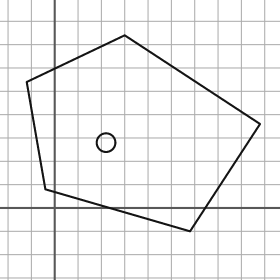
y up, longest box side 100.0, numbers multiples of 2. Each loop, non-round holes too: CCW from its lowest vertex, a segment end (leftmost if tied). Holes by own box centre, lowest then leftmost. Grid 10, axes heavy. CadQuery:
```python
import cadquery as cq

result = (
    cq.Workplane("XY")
    .moveTo(58.0, -10.0)
    .lineTo(88.0, 36.0)
    .lineTo(30.0, 74.0)
    .lineTo(-12.0, 54.0)
    .lineTo(-4.0, 8.0)
    .close()
    .moveTo(22.0, 28.0)
    .circle(4.0)
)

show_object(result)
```